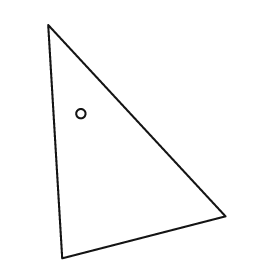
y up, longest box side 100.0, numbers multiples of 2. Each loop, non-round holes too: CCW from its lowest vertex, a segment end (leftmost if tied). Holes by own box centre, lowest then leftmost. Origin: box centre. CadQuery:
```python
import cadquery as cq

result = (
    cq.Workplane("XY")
    .moveTo(-32.0, -50.0)
    .lineTo(38.0, -32.0)
    .lineTo(-38.0, 50.0)
    .close()
    .moveTo(-24.0, 12.0)
    .circle(2.0)
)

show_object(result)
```